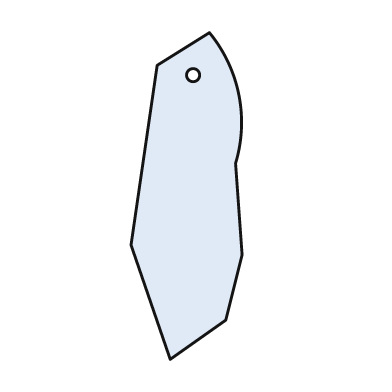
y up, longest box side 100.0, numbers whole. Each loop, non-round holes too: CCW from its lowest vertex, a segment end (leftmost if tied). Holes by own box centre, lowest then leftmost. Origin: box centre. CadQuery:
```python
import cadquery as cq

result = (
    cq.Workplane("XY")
    .moveTo(-5.0, -50.0)
    .lineTo(12.0, -38.0)
    .lineTo(17.0, -18.0)
    .lineTo(15.0, 10.0)
    .threePointArc((16.0, 31.0), (7.0, 50.0))
    .lineTo(-9.0, 40.0)
    .lineTo(-17.0, -15.0)
    .close()
    .moveTo(2.0, 37.0)
    .circle(2.0)
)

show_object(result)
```